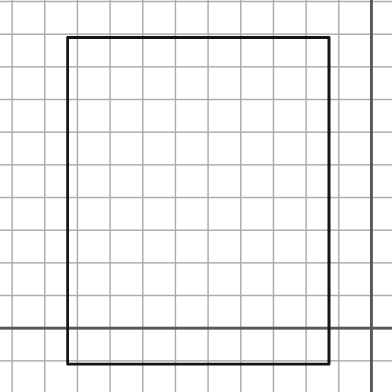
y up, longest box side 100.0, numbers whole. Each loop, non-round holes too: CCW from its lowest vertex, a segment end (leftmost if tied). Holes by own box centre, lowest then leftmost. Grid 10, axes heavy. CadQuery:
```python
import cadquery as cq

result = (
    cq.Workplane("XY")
    .moveTo(-93.0, -11.0)
    .lineTo(-13.0, -11.0)
    .lineTo(-13.0, 89.0)
    .lineTo(-93.0, 89.0)
    .close()
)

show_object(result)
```